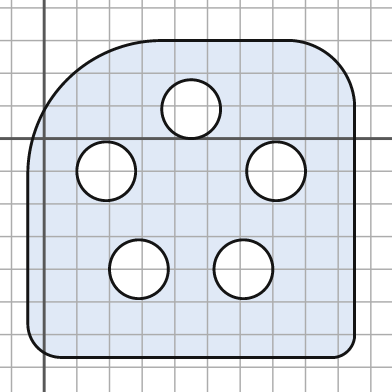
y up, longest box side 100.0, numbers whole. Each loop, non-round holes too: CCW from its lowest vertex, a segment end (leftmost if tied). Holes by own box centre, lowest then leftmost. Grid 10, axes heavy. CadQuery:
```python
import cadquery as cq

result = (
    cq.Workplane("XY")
    .moveTo(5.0, -67.0)
    .lineTo(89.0, -67.0)
    .threePointArc((93.0, -65.0), (95.0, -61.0))
    .lineTo(95.0, 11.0)
    .threePointArc((89.0, 24.0), (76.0, 30.0))
    .lineTo(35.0, 30.0)
    .threePointArc((7.0, 18.0), (-5.0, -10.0))
    .lineTo(-5.0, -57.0)
    .threePointArc((-2.0, -64.0), (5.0, -67.0))
    .close()
    .moveTo(29.0, -40.0)
    .circle(9.0)
    .moveTo(61.0, -40.0)
    .circle(9.0)
    .moveTo(19.0, -10.0)
    .circle(9.0)
    .moveTo(71.0, -10.0)
    .circle(9.0)
    .moveTo(45.0, 9.0)
    .circle(9.0)
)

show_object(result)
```